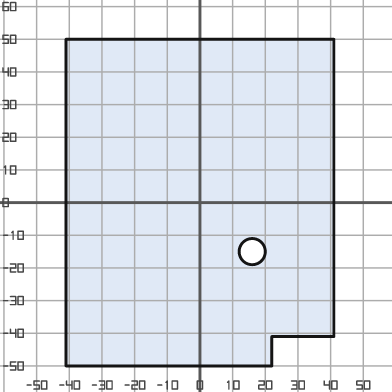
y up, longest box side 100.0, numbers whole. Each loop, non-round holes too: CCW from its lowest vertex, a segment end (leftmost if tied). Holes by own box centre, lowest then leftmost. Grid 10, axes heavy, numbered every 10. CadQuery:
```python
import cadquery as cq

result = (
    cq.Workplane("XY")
    .moveTo(-41.0, -50.0)
    .lineTo(22.0, -50.0)
    .lineTo(22.0, -41.0)
    .lineTo(41.0, -41.0)
    .lineTo(41.0, 50.0)
    .lineTo(-41.0, 50.0)
    .close()
    .moveTo(16.0, -15.0)
    .circle(4.0)
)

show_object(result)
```